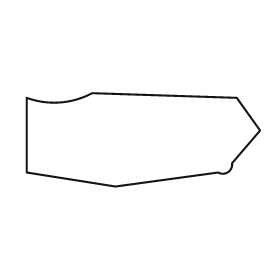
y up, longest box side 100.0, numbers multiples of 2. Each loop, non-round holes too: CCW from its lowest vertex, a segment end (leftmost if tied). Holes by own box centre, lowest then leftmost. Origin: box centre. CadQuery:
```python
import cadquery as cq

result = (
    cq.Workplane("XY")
    .moveTo(-12.0, -20.0)
    .lineTo(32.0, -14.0)
    .threePointArc((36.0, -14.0), (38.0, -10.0))
    .lineTo(50.0, 4.0)
    .lineTo(40.0, 18.0)
    .lineTo(-22.0, 20.0)
    .threePointArc((-36.0, 16.0), (-50.0, 18.0))
    .lineTo(-50.0, -14.0)
    .close()
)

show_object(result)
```